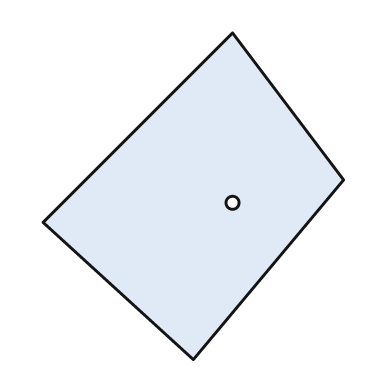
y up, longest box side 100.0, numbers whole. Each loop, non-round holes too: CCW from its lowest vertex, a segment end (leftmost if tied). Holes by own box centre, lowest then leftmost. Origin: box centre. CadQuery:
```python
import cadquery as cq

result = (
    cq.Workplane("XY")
    .moveTo(0.0, -50.0)
    .lineTo(46.0, 5.0)
    .lineTo(12.0, 50.0)
    .lineTo(-46.0, -8.0)
    .close()
    .moveTo(12.0, -2.0)
    .circle(2.0)
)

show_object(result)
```